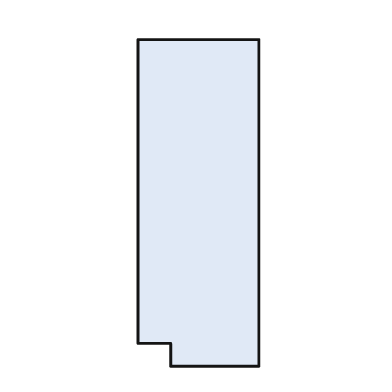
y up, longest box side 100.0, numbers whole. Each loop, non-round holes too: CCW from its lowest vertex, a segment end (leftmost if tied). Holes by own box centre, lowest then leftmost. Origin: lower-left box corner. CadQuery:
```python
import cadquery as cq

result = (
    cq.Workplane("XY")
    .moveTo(10.0, 0.0)
    .lineTo(37.0, 0.0)
    .lineTo(37.0, 100.0)
    .lineTo(0.0, 100.0)
    .lineTo(0.0, 7.0)
    .lineTo(10.0, 7.0)
    .close()
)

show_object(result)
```